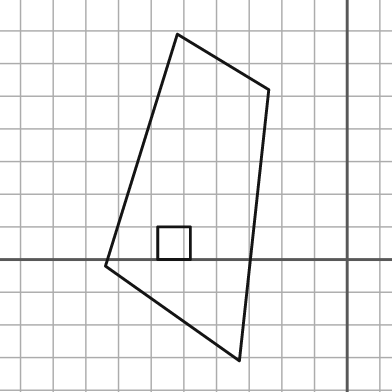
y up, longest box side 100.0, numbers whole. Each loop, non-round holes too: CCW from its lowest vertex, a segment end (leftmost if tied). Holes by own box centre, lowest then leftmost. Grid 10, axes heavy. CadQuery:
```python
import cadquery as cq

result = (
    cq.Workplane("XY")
    .moveTo(-33.0, -31.0)
    .lineTo(-24.0, 52.0)
    .lineTo(-52.0, 69.0)
    .lineTo(-74.0, -2.0)
    .close()
    .moveTo(-58.0, 0.0)
    .lineTo(-48.0, 0.0)
    .lineTo(-48.0, 10.0)
    .lineTo(-58.0, 10.0)
    .close()
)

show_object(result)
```